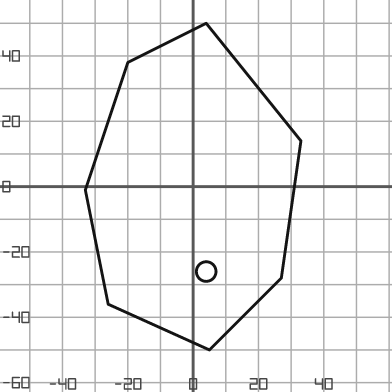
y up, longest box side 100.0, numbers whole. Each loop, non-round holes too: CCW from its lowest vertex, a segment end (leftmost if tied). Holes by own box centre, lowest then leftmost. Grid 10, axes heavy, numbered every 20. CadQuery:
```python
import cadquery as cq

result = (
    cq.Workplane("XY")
    .moveTo(5.0, -50.0)
    .lineTo(27.0, -28.0)
    .lineTo(33.0, 14.0)
    .lineTo(4.0, 50.0)
    .lineTo(-20.0, 38.0)
    .lineTo(-33.0, -1.0)
    .lineTo(-26.0, -36.0)
    .close()
    .moveTo(4.0, -26.0)
    .circle(3.0)
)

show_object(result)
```